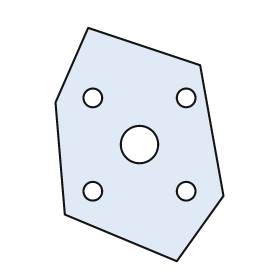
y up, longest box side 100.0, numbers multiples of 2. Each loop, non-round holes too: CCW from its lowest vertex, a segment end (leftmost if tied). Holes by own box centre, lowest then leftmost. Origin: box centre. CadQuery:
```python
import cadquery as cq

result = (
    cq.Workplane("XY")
    .moveTo(16.0, -50.0)
    .lineTo(36.0, -22.0)
    .lineTo(26.0, 34.0)
    .lineTo(-22.0, 50.0)
    .lineTo(-36.0, 18.0)
    .lineTo(-32.0, -30.0)
    .close()
    .moveTo(-20.0, -20.0)
    .circle(4.0)
    .moveTo(20.0, -20.0)
    .circle(4.0)
    .moveTo(0.0, 0.0)
    .circle(8.0)
    .moveTo(-20.0, 20.0)
    .circle(4.0)
    .moveTo(20.0, 20.0)
    .circle(4.0)
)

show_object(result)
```